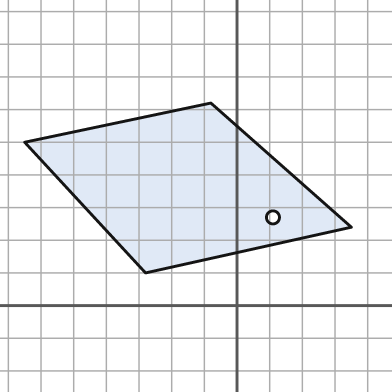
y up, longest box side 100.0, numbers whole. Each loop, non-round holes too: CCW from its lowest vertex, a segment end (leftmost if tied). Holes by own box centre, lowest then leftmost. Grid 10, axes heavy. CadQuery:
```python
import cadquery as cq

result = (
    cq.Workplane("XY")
    .moveTo(-28.0, 10.0)
    .lineTo(35.0, 24.0)
    .lineTo(-8.0, 62.0)
    .lineTo(-65.0, 50.0)
    .close()
    .moveTo(11.0, 27.0)
    .circle(2.0)
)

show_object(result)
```